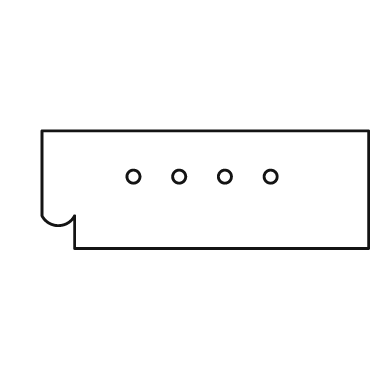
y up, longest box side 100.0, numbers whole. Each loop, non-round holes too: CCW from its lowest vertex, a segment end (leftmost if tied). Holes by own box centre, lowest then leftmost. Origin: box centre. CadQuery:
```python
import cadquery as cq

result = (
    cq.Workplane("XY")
    .moveTo(-40.0, -18.0)
    .lineTo(50.0, -18.0)
    .lineTo(50.0, 18.0)
    .lineTo(-50.0, 18.0)
    .lineTo(-50.0, -8.0)
    .threePointArc((-45.0, -11.0), (-40.0, -8.0))
    .close()
    .moveTo(-22.0, 4.0)
    .circle(2.0)
    .moveTo(-8.0, 4.0)
    .circle(2.0)
    .moveTo(6.0, 4.0)
    .circle(2.0)
    .moveTo(20.0, 4.0)
    .circle(2.0)
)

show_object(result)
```